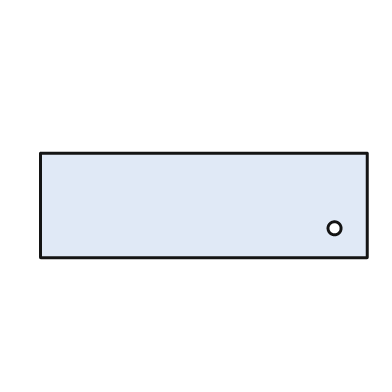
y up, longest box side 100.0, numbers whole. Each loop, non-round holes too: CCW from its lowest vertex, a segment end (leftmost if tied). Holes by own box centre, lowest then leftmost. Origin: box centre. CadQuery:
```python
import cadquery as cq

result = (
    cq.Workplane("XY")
    .moveTo(-50.0, -16.0)
    .lineTo(50.0, -16.0)
    .lineTo(50.0, 16.0)
    .lineTo(-50.0, 16.0)
    .close()
    .moveTo(40.0, -7.0)
    .circle(2.0)
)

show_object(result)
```